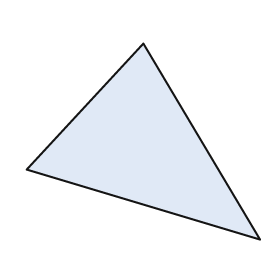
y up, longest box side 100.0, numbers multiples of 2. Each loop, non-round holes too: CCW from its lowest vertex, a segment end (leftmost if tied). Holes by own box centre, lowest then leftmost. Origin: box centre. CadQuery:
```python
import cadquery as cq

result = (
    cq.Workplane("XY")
    .moveTo(50.0, -42.0)
    .lineTo(0.0, 42.0)
    .lineTo(-50.0, -12.0)
    .close()
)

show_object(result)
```